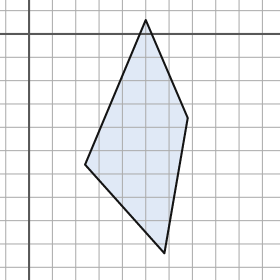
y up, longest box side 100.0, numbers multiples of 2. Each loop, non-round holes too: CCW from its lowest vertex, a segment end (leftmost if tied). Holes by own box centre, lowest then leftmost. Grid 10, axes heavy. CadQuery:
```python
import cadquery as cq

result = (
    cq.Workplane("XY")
    .moveTo(58.0, -94.0)
    .lineTo(68.0, -36.0)
    .lineTo(50.0, 6.0)
    .lineTo(24.0, -56.0)
    .close()
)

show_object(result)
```